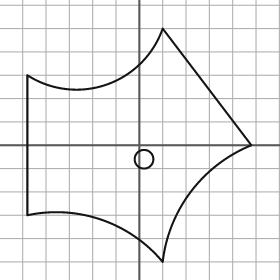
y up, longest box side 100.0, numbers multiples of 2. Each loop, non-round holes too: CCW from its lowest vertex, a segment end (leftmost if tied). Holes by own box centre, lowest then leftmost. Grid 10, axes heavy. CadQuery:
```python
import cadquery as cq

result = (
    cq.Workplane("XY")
    .moveTo(10.0, -50.0)
    .threePointArc((22.0, -20.0), (48.0, 0.0))
    .lineTo(10.0, 50.0)
    .threePointArc((-14.0, 26.0), (-48.0, 30.0))
    .lineTo(-48.0, -30.0)
    .threePointArc((-16.0, -32.0), (10.0, -50.0))
    .close()
    .moveTo(2.0, -6.0)
    .circle(4.0)
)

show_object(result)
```